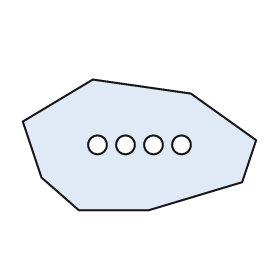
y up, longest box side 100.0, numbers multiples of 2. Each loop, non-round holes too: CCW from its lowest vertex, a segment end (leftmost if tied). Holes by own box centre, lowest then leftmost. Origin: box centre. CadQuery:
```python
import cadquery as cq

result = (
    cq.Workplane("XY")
    .moveTo(-26.0, -28.0)
    .lineTo(4.0, -28.0)
    .lineTo(44.0, -16.0)
    .lineTo(50.0, 2.0)
    .lineTo(22.0, 22.0)
    .lineTo(-20.0, 28.0)
    .lineTo(-50.0, 10.0)
    .lineTo(-42.0, -14.0)
    .close()
    .moveTo(-18.0, 0.0)
    .circle(4.0)
    .moveTo(-6.0, 0.0)
    .circle(4.0)
    .moveTo(6.0, 0.0)
    .circle(4.0)
    .moveTo(18.0, 0.0)
    .circle(4.0)
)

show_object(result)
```